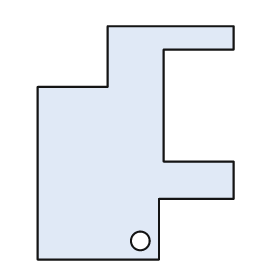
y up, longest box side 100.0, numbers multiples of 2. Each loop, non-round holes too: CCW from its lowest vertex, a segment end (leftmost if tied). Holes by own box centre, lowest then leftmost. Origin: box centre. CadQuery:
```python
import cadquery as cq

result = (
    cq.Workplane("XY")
    .moveTo(-42.0, -50.0)
    .lineTo(10.0, -50.0)
    .lineTo(10.0, -24.0)
    .lineTo(42.0, -24.0)
    .lineTo(42.0, -8.0)
    .lineTo(12.0, -8.0)
    .lineTo(12.0, 40.0)
    .lineTo(42.0, 40.0)
    .lineTo(42.0, 50.0)
    .lineTo(-12.0, 50.0)
    .lineTo(-12.0, 24.0)
    .lineTo(-42.0, 24.0)
    .close()
    .moveTo(2.0, -42.0)
    .circle(4.0)
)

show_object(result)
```